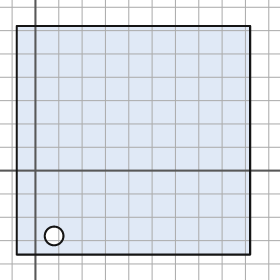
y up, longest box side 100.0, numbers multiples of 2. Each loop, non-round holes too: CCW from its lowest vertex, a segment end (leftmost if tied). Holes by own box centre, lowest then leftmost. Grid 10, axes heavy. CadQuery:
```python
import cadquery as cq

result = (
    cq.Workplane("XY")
    .moveTo(-8.0, -36.0)
    .lineTo(92.0, -36.0)
    .lineTo(92.0, 62.0)
    .lineTo(-8.0, 62.0)
    .close()
    .moveTo(8.0, -28.0)
    .circle(4.0)
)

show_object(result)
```